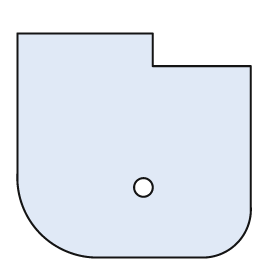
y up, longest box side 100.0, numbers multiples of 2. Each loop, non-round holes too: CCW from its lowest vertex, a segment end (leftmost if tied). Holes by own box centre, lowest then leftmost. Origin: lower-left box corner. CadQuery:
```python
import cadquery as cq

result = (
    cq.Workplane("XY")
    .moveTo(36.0, 0.0)
    .lineTo(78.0, 0.0)
    .threePointArc((94.0, 6.0), (100.0, 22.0))
    .lineTo(100.0, 82.0)
    .lineTo(58.0, 82.0)
    .lineTo(58.0, 96.0)
    .lineTo(0.0, 96.0)
    .lineTo(0.0, 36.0)
    .threePointArc((10.0, 10.0), (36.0, 0.0))
    .close()
    .moveTo(54.0, 30.0)
    .circle(4.0)
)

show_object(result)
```